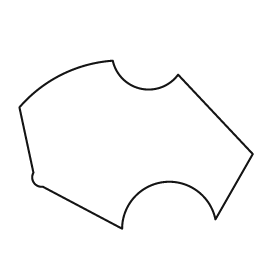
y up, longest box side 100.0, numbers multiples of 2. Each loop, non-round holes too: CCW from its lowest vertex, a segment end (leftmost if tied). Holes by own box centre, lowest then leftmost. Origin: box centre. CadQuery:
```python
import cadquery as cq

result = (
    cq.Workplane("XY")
    .moveTo(-6.0, -36.0)
    .threePointArc((12.0, -16.0), (34.0, -32.0))
    .lineTo(50.0, -4.0)
    .lineTo(18.0, 30.0)
    .threePointArc((2.0, 24.0), (-10.0, 36.0))
    .threePointArc((-32.0, 30.0), (-50.0, 16.0))
    .lineTo(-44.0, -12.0)
    .threePointArc((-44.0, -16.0), (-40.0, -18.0))
    .close()
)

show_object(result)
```